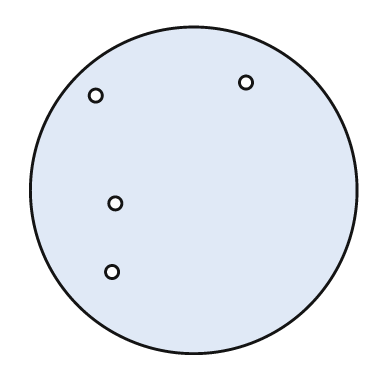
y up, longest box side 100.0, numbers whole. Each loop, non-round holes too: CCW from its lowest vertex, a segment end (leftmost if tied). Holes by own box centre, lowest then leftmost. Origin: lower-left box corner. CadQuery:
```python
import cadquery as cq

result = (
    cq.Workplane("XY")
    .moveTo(50.0, 50.0)
    .circle(50.0)
    .moveTo(25.0, 25.0)
    .circle(2.0)
    .moveTo(26.0, 46.0)
    .circle(2.0)
    .moveTo(20.0, 79.0)
    .circle(2.0)
    .moveTo(66.0, 83.0)
    .circle(2.0)
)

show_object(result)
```